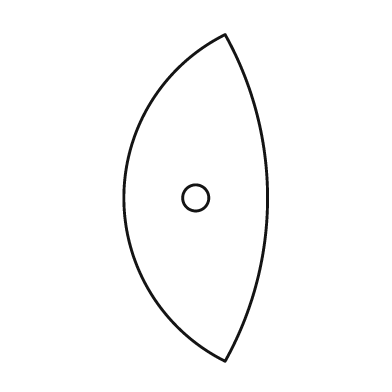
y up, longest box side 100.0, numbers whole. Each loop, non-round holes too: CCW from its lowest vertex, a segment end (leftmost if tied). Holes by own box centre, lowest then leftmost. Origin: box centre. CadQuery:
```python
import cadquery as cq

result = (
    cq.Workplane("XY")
    .moveTo(9.0, -50.0)
    .threePointArc((22.0, 0.0), (9.0, 50.0))
    .threePointArc((-22.0, 0.0), (9.0, -50.0))
    .close()
    .moveTo(0.0, 0.0)
    .circle(4.0)
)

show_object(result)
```